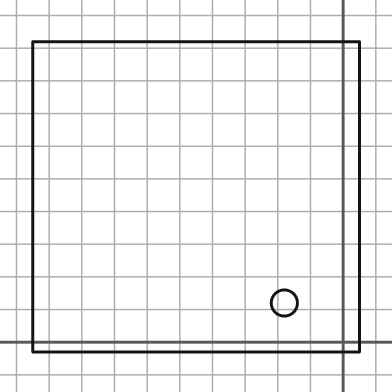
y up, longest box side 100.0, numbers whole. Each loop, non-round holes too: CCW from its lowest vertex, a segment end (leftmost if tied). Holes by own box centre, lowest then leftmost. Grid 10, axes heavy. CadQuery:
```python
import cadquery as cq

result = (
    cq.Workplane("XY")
    .moveTo(-95.0, -3.0)
    .lineTo(5.0, -3.0)
    .lineTo(5.0, 92.0)
    .lineTo(-95.0, 92.0)
    .close()
    .moveTo(-18.0, 12.0)
    .circle(4.0)
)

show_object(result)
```